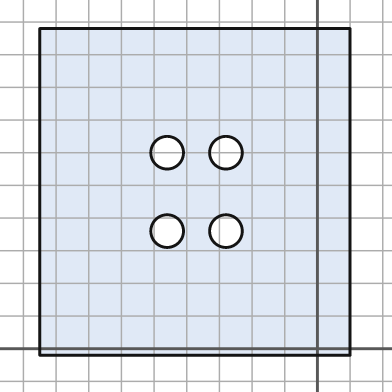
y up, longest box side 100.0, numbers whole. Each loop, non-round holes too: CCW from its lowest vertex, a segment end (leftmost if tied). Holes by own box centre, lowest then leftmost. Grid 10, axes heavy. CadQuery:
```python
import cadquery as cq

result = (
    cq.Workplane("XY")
    .moveTo(-85.0, -2.0)
    .lineTo(10.0, -2.0)
    .lineTo(10.0, 98.0)
    .lineTo(-85.0, 98.0)
    .close()
    .moveTo(-46.0, 36.0)
    .circle(5.0)
    .moveTo(-28.0, 36.0)
    .circle(5.0)
    .moveTo(-46.0, 60.0)
    .circle(5.0)
    .moveTo(-28.0, 60.0)
    .circle(5.0)
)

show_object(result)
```